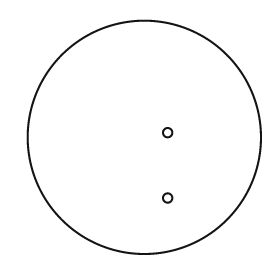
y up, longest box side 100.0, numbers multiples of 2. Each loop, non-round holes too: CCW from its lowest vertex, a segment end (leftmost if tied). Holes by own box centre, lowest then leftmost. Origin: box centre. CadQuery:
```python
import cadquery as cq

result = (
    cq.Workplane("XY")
    .moveTo(0.0, 0.0)
    .circle(50.0)
    .moveTo(10.0, -26.0)
    .circle(2.0)
    .moveTo(10.0, 2.0)
    .circle(2.0)
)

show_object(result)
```